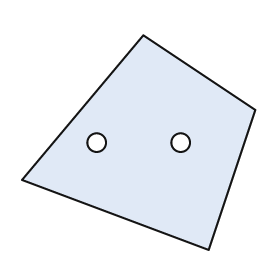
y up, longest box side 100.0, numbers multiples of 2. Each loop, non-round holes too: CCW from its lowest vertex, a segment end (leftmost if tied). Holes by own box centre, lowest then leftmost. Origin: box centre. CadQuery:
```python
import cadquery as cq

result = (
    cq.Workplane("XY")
    .moveTo(30.0, -46.0)
    .lineTo(50.0, 14.0)
    .lineTo(2.0, 46.0)
    .lineTo(-50.0, -16.0)
    .close()
    .moveTo(-18.0, 0.0)
    .circle(4.0)
    .moveTo(18.0, 0.0)
    .circle(4.0)
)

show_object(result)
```